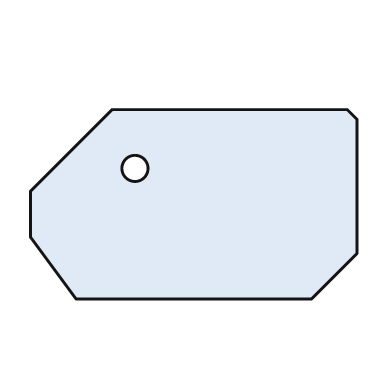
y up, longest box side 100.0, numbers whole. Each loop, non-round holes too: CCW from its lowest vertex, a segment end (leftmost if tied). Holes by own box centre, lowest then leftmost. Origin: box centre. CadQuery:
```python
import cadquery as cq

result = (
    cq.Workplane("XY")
    .moveTo(-36.0, -29.0)
    .lineTo(36.0, -29.0)
    .lineTo(50.0, -15.0)
    .lineTo(50.0, 26.0)
    .lineTo(47.0, 29.0)
    .lineTo(-25.0, 29.0)
    .lineTo(-50.0, 4.0)
    .lineTo(-50.0, -10.0)
    .close()
    .moveTo(-18.0, 11.0)
    .circle(4.0)
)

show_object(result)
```